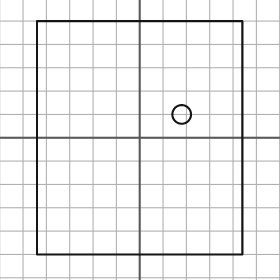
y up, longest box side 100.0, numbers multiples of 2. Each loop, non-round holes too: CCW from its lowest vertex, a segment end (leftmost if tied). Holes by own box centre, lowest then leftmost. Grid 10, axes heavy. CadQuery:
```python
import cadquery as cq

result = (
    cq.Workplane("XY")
    .moveTo(-44.0, -50.0)
    .lineTo(44.0, -50.0)
    .lineTo(44.0, 50.0)
    .lineTo(-44.0, 50.0)
    .close()
    .moveTo(18.0, 10.0)
    .circle(4.0)
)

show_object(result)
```